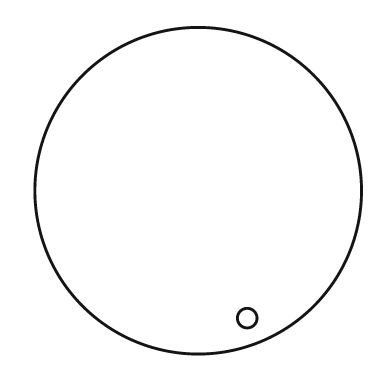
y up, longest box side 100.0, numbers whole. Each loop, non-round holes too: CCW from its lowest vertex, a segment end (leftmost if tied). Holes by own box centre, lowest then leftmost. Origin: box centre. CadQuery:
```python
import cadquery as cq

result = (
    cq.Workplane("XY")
    .moveTo(0.0, 0.0)
    .circle(50.0)
    .moveTo(15.0, -39.0)
    .circle(3.0)
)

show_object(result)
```